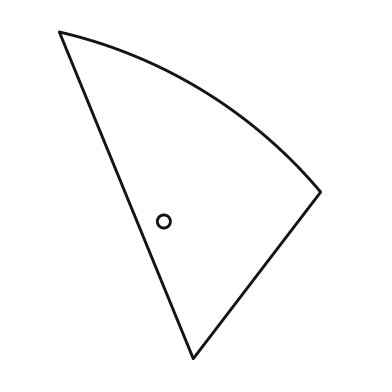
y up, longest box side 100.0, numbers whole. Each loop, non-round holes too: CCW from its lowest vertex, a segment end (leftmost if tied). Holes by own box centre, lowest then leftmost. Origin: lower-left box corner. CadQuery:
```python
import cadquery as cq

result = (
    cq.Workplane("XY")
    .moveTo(41.0, 0.0)
    .lineTo(80.0, 51.0)
    .threePointArc((44.0, 82.0), (0.0, 100.0))
    .close()
    .moveTo(32.0, 42.0)
    .circle(2.0)
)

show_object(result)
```